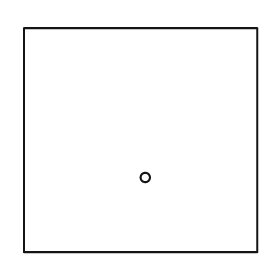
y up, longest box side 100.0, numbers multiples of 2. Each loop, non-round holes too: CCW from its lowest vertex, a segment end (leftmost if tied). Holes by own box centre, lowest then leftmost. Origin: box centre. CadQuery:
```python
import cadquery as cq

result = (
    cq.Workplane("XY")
    .moveTo(-50.0, -48.0)
    .lineTo(50.0, -48.0)
    .lineTo(50.0, 48.0)
    .lineTo(-50.0, 48.0)
    .close()
    .moveTo(2.0, -16.0)
    .circle(2.0)
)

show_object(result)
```